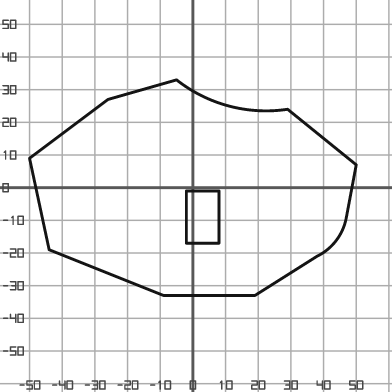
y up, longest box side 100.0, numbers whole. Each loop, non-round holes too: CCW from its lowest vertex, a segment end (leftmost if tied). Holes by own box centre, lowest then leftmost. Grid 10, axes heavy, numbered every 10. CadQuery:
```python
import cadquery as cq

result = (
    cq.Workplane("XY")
    .moveTo(-9.0, -33.0)
    .lineTo(19.0, -33.0)
    .lineTo(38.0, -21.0)
    .threePointArc((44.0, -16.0), (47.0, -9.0))
    .lineTo(50.0, 7.0)
    .lineTo(29.0, 24.0)
    .threePointArc((11.0, 25.0), (-5.0, 33.0))
    .lineTo(-26.0, 27.0)
    .lineTo(-50.0, 9.0)
    .lineTo(-44.0, -19.0)
    .close()
    .moveTo(-2.0, -17.0)
    .lineTo(8.0, -17.0)
    .lineTo(8.0, -1.0)
    .lineTo(-2.0, -1.0)
    .close()
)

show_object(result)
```